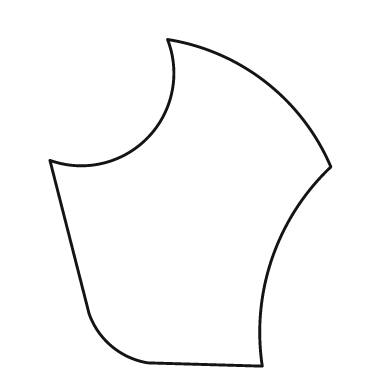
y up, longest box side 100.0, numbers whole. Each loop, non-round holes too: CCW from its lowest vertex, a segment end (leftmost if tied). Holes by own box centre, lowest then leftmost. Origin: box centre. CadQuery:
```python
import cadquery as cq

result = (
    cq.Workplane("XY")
    .moveTo(22.0, -50.0)
    .threePointArc((25.0, -17.0), (43.0, 11.0))
    .threePointArc((23.0, 37.0), (-7.0, 50.0))
    .threePointArc((-13.0, 20.0), (-43.0, 13.0))
    .lineTo(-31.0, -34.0)
    .threePointArc((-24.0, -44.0), (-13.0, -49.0))
    .close()
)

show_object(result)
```